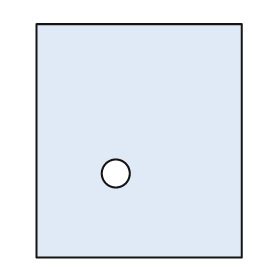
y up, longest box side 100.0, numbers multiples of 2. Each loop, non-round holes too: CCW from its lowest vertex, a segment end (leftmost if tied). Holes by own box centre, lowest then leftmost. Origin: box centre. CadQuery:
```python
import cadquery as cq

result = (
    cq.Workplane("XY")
    .moveTo(-44.0, -50.0)
    .lineTo(44.0, -50.0)
    .lineTo(44.0, 50.0)
    .lineTo(-44.0, 50.0)
    .close()
    .moveTo(-10.0, -14.0)
    .circle(6.0)
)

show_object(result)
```